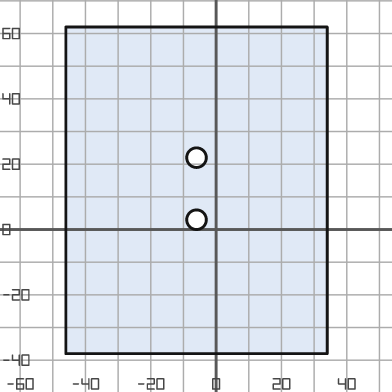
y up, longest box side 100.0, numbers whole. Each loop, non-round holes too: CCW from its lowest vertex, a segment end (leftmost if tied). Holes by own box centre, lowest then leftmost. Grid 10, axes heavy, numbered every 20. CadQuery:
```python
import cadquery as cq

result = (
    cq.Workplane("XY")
    .moveTo(-46.0, -38.0)
    .lineTo(34.0, -38.0)
    .lineTo(34.0, 62.0)
    .lineTo(-46.0, 62.0)
    .close()
    .moveTo(-6.0, 3.0)
    .circle(3.0)
    .moveTo(-6.0, 22.0)
    .circle(3.0)
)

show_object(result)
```